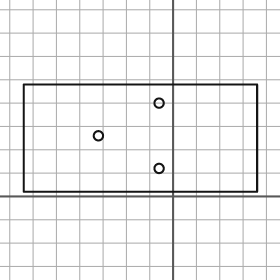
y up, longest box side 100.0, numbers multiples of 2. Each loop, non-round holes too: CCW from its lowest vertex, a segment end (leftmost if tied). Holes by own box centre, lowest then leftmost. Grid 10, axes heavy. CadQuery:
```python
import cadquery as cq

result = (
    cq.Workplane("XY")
    .moveTo(-64.0, 2.0)
    .lineTo(36.0, 2.0)
    .lineTo(36.0, 48.0)
    .lineTo(-64.0, 48.0)
    .close()
    .moveTo(-6.0, 12.0)
    .circle(2.0)
    .moveTo(-32.0, 26.0)
    .circle(2.0)
    .moveTo(-6.0, 40.0)
    .circle(2.0)
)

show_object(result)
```